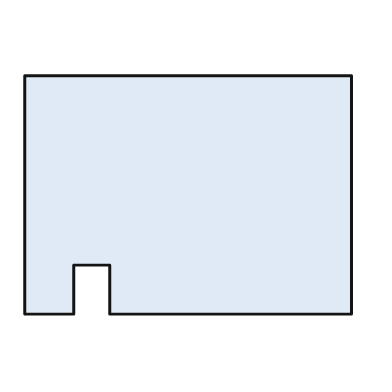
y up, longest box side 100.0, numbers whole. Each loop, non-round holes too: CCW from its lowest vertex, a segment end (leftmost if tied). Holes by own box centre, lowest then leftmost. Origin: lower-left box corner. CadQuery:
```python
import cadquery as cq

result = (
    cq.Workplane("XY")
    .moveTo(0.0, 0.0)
    .lineTo(15.0, 0.0)
    .lineTo(15.0, 15.0)
    .lineTo(26.0, 15.0)
    .lineTo(26.0, 0.0)
    .lineTo(100.0, 0.0)
    .lineTo(100.0, 73.0)
    .lineTo(0.0, 73.0)
    .close()
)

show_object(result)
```